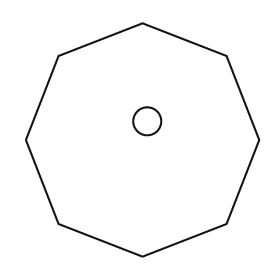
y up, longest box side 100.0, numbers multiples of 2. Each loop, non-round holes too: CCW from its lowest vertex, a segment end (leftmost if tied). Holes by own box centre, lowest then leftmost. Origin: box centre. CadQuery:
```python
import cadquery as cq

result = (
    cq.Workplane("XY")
    .moveTo(0.0, -50.0)
    .lineTo(36.0, -36.0)
    .lineTo(50.0, 0.0)
    .lineTo(36.0, 36.0)
    .lineTo(0.0, 50.0)
    .lineTo(-36.0, 36.0)
    .lineTo(-50.0, 0.0)
    .lineTo(-36.0, -36.0)
    .close()
    .moveTo(2.0, 8.0)
    .circle(6.0)
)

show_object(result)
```